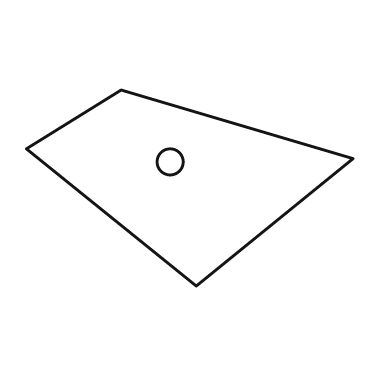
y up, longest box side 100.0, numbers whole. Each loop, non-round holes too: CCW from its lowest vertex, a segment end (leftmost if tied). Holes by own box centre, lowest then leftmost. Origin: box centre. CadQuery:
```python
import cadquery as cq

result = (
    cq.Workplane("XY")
    .moveTo(2.0, -30.0)
    .lineTo(50.0, 9.0)
    .lineTo(-21.0, 30.0)
    .lineTo(-50.0, 12.0)
    .close()
    .moveTo(-6.0, 8.0)
    .circle(4.0)
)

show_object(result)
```